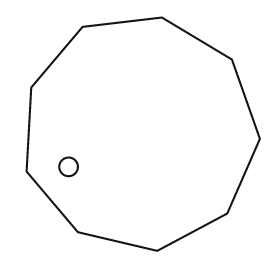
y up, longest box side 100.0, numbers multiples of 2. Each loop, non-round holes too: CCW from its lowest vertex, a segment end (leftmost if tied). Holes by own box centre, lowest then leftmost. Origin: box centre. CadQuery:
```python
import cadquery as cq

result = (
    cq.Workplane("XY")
    .moveTo(6.0, -50.0)
    .lineTo(36.0, -34.0)
    .lineTo(50.0, -2.0)
    .lineTo(38.0, 32.0)
    .lineTo(8.0, 50.0)
    .lineTo(-26.0, 46.0)
    .lineTo(-48.0, 20.0)
    .lineTo(-50.0, -16.0)
    .lineTo(-28.0, -42.0)
    .close()
    .moveTo(-32.0, -14.0)
    .circle(4.0)
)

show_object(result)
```